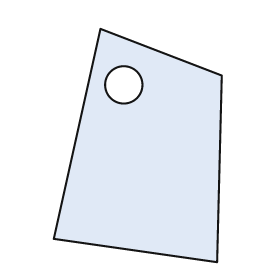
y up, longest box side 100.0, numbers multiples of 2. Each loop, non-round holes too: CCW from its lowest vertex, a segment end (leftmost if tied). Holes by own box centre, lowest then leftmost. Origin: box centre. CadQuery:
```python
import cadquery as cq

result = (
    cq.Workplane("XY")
    .moveTo(34.0, -50.0)
    .lineTo(36.0, 30.0)
    .lineTo(-16.0, 50.0)
    .lineTo(-36.0, -40.0)
    .close()
    .moveTo(-6.0, 26.0)
    .circle(8.0)
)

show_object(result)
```